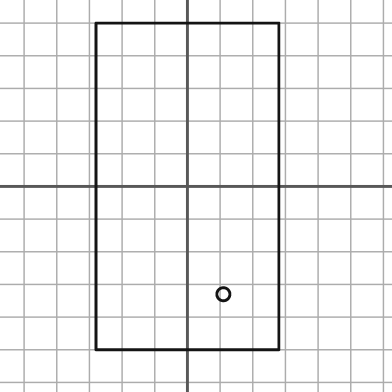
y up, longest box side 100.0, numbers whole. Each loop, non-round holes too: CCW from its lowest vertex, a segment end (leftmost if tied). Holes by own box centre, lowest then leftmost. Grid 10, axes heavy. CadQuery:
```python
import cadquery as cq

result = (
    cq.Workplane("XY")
    .moveTo(-28.0, -50.0)
    .lineTo(28.0, -50.0)
    .lineTo(28.0, 50.0)
    .lineTo(-28.0, 50.0)
    .close()
    .moveTo(11.0, -33.0)
    .circle(2.0)
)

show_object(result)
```